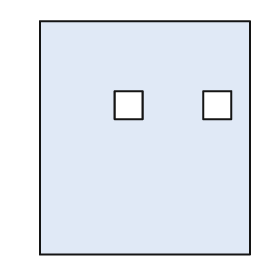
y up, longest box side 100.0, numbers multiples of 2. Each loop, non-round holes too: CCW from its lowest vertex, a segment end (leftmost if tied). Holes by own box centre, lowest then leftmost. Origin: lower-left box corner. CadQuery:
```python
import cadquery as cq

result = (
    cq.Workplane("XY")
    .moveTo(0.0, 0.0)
    .lineTo(90.0, 0.0)
    .lineTo(90.0, 100.0)
    .lineTo(0.0, 100.0)
    .close()
    .moveTo(32.0, 58.0)
    .lineTo(44.0, 58.0)
    .lineTo(44.0, 70.0)
    .lineTo(32.0, 70.0)
    .close()
    .moveTo(70.0, 58.0)
    .lineTo(82.0, 58.0)
    .lineTo(82.0, 70.0)
    .lineTo(70.0, 70.0)
    .close()
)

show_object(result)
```